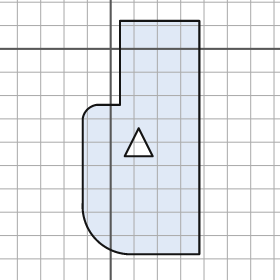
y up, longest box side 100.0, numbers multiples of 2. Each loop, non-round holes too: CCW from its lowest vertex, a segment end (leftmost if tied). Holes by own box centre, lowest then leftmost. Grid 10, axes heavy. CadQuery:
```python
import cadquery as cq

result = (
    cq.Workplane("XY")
    .moveTo(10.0, -88.0)
    .lineTo(38.0, -88.0)
    .lineTo(38.0, 12.0)
    .lineTo(4.0, 12.0)
    .lineTo(4.0, -24.0)
    .lineTo(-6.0, -24.0)
    .threePointArc((-10.0, -26.0), (-12.0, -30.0))
    .lineTo(-12.0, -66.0)
    .threePointArc((-6.0, -82.0), (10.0, -88.0))
    .close()
    .moveTo(6.0, -46.0)
    .lineTo(18.0, -46.0)
    .lineTo(12.0, -34.0)
    .close()
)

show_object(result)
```